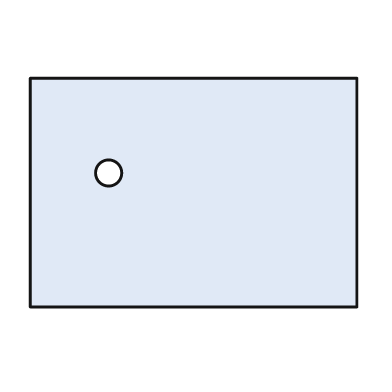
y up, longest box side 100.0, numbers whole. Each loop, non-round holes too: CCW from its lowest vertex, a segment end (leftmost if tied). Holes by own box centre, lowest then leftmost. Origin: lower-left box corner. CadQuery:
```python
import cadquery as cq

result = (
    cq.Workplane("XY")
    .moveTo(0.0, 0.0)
    .lineTo(100.0, 0.0)
    .lineTo(100.0, 70.0)
    .lineTo(0.0, 70.0)
    .close()
    .moveTo(24.0, 41.0)
    .circle(4.0)
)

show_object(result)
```